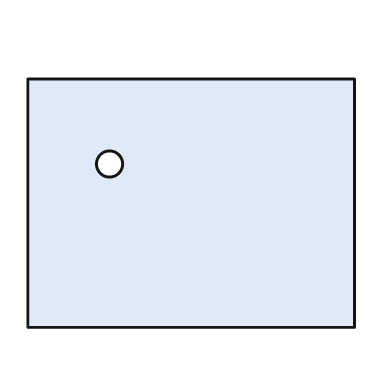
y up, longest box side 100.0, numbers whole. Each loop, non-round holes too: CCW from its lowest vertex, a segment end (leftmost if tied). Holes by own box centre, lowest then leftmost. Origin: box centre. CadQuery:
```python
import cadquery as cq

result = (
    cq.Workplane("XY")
    .moveTo(-50.0, -38.0)
    .lineTo(50.0, -38.0)
    .lineTo(50.0, 38.0)
    .lineTo(-50.0, 38.0)
    .close()
    .moveTo(-25.0, 12.0)
    .circle(4.0)
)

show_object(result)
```